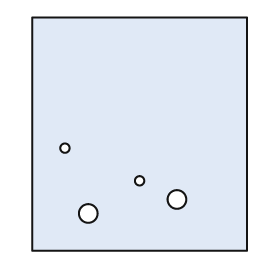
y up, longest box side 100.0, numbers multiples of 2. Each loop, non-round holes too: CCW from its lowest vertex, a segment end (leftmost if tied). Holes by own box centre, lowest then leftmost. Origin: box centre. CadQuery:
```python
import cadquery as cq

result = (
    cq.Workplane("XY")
    .moveTo(-46.0, -50.0)
    .lineTo(46.0, -50.0)
    .lineTo(46.0, 50.0)
    .lineTo(-46.0, 50.0)
    .close()
    .moveTo(-22.0, -34.0)
    .circle(4.0)
    .moveTo(16.0, -28.0)
    .circle(4.0)
    .moveTo(0.0, -20.0)
    .circle(2.0)
    .moveTo(-32.0, -6.0)
    .circle(2.0)
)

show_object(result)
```